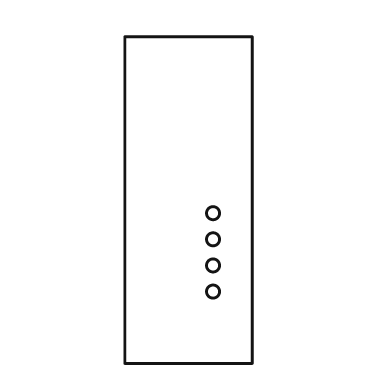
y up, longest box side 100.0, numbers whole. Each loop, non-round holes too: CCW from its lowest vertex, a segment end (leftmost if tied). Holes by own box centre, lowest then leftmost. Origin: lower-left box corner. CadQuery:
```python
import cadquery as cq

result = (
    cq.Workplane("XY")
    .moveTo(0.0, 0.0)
    .lineTo(39.0, 0.0)
    .lineTo(39.0, 100.0)
    .lineTo(0.0, 100.0)
    .close()
    .moveTo(27.0, 22.0)
    .circle(2.0)
    .moveTo(27.0, 30.0)
    .circle(2.0)
    .moveTo(27.0, 38.0)
    .circle(2.0)
    .moveTo(27.0, 46.0)
    .circle(2.0)
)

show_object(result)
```